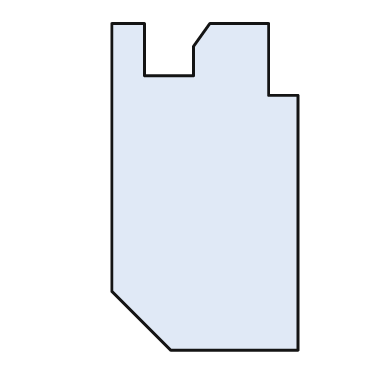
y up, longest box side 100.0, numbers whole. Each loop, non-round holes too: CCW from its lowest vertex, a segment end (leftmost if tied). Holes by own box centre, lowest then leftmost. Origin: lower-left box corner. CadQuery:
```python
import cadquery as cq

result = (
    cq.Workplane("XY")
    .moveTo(18.0, 0.0)
    .lineTo(57.0, 0.0)
    .lineTo(57.0, 78.0)
    .lineTo(48.0, 78.0)
    .lineTo(48.0, 100.0)
    .lineTo(30.0, 100.0)
    .lineTo(25.0, 93.0)
    .lineTo(25.0, 84.0)
    .lineTo(10.0, 84.0)
    .lineTo(10.0, 100.0)
    .lineTo(0.0, 100.0)
    .lineTo(0.0, 18.0)
    .close()
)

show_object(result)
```